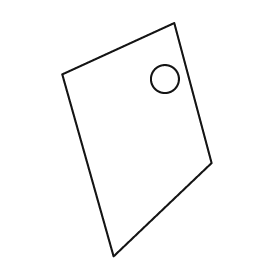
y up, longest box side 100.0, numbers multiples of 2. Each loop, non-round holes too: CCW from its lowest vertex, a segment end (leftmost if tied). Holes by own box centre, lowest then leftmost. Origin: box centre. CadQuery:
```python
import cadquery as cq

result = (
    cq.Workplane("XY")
    .moveTo(-10.0, -50.0)
    .lineTo(32.0, -10.0)
    .lineTo(16.0, 50.0)
    .lineTo(-32.0, 28.0)
    .close()
    .moveTo(12.0, 26.0)
    .circle(6.0)
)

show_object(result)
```